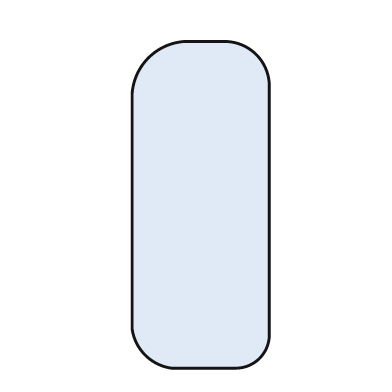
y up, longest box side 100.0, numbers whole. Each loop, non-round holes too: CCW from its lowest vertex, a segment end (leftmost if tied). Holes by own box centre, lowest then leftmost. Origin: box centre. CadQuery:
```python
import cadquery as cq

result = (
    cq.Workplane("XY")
    .moveTo(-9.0, -50.0)
    .lineTo(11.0, -50.0)
    .threePointArc((18.0, -47.0), (21.0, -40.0))
    .lineTo(21.0, 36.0)
    .threePointArc((17.0, 46.0), (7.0, 50.0))
    .lineTo(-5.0, 50.0)
    .threePointArc((-16.0, 45.0), (-21.0, 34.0))
    .lineTo(-21.0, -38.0)
    .threePointArc((-17.0, -46.0), (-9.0, -50.0))
    .close()
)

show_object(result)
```